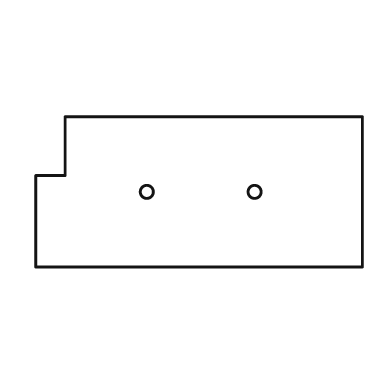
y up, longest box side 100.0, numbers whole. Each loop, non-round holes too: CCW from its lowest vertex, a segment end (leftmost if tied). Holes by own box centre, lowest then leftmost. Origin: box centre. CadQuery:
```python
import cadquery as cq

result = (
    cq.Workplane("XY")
    .moveTo(-50.0, -23.0)
    .lineTo(50.0, -23.0)
    .lineTo(50.0, 23.0)
    .lineTo(-41.0, 23.0)
    .lineTo(-41.0, 5.0)
    .lineTo(-50.0, 5.0)
    .close()
    .moveTo(-16.0, 0.0)
    .circle(2.0)
    .moveTo(17.0, 0.0)
    .circle(2.0)
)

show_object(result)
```